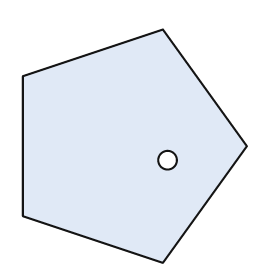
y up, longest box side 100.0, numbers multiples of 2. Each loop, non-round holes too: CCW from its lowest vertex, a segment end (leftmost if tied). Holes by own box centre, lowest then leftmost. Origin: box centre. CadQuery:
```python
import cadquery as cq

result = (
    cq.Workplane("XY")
    .moveTo(12.0, -50.0)
    .lineTo(48.0, 0.0)
    .lineTo(12.0, 50.0)
    .lineTo(-48.0, 30.0)
    .lineTo(-48.0, -30.0)
    .close()
    .moveTo(14.0, -6.0)
    .circle(4.0)
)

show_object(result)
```